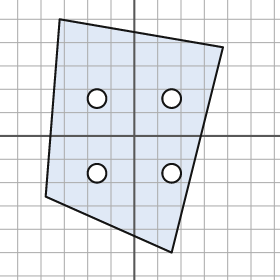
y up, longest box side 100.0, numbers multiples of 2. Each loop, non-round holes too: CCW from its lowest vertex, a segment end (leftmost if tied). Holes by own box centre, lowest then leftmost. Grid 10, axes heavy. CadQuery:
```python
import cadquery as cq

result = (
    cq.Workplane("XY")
    .moveTo(16.0, -50.0)
    .lineTo(38.0, 38.0)
    .lineTo(-32.0, 50.0)
    .lineTo(-38.0, -26.0)
    .close()
    .moveTo(-16.0, -16.0)
    .circle(4.0)
    .moveTo(16.0, -16.0)
    .circle(4.0)
    .moveTo(-16.0, 16.0)
    .circle(4.0)
    .moveTo(16.0, 16.0)
    .circle(4.0)
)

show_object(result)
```